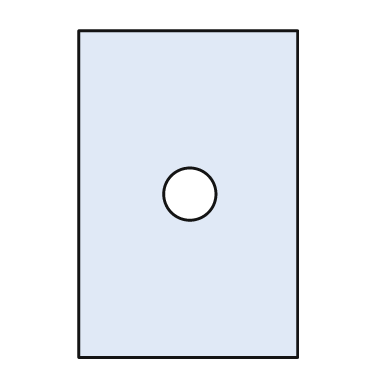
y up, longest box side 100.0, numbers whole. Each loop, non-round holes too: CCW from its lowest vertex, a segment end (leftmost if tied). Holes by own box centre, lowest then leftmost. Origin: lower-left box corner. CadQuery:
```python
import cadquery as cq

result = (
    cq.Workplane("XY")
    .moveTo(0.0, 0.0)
    .lineTo(67.0, 0.0)
    .lineTo(67.0, 100.0)
    .lineTo(0.0, 100.0)
    .close()
    .moveTo(34.0, 50.0)
    .circle(8.0)
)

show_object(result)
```